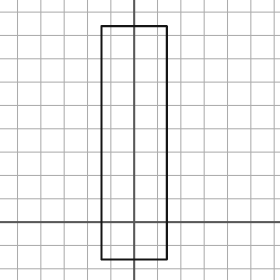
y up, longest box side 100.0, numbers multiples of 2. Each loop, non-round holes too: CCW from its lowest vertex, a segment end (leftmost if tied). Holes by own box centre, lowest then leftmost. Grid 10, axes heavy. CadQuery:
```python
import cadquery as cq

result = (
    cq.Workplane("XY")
    .moveTo(-14.0, -16.0)
    .lineTo(14.0, -16.0)
    .lineTo(14.0, 84.0)
    .lineTo(-14.0, 84.0)
    .close()
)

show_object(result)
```